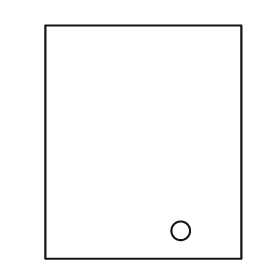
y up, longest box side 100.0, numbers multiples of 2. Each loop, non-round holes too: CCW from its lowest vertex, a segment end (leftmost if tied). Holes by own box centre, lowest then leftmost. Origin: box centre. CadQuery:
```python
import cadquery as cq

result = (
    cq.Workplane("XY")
    .moveTo(-42.0, -50.0)
    .lineTo(42.0, -50.0)
    .lineTo(42.0, 50.0)
    .lineTo(-42.0, 50.0)
    .close()
    .moveTo(16.0, -38.0)
    .circle(4.0)
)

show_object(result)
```